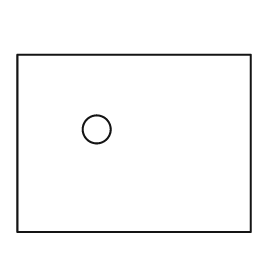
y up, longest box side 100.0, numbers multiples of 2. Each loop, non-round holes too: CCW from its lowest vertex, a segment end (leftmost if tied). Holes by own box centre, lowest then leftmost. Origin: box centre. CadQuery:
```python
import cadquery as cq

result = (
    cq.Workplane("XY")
    .moveTo(-50.0, -38.0)
    .lineTo(50.0, -38.0)
    .lineTo(50.0, 38.0)
    .lineTo(-50.0, 38.0)
    .close()
    .moveTo(-16.0, 6.0)
    .circle(6.0)
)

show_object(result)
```